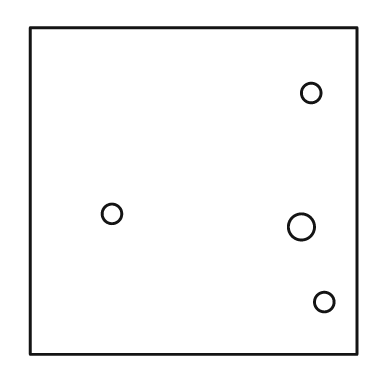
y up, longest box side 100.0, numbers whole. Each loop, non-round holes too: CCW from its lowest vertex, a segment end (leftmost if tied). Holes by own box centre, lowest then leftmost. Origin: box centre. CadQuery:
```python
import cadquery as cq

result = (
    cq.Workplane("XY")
    .moveTo(-50.0, -50.0)
    .lineTo(50.0, -50.0)
    .lineTo(50.0, 50.0)
    .lineTo(-50.0, 50.0)
    .close()
    .moveTo(40.0, -34.0)
    .circle(3.0)
    .moveTo(33.0, -11.0)
    .circle(4.0)
    .moveTo(-25.0, -7.0)
    .circle(3.0)
    .moveTo(36.0, 30.0)
    .circle(3.0)
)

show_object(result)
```